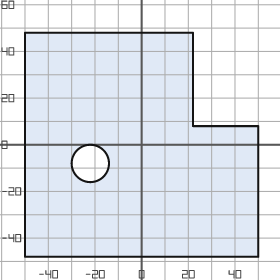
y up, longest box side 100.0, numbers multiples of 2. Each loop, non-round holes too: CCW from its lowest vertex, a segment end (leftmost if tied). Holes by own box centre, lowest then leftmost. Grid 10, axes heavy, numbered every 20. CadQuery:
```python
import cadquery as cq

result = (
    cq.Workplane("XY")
    .moveTo(-50.0, -48.0)
    .lineTo(50.0, -48.0)
    .lineTo(50.0, 8.0)
    .lineTo(22.0, 8.0)
    .lineTo(22.0, 48.0)
    .lineTo(-50.0, 48.0)
    .close()
    .moveTo(-22.0, -8.0)
    .circle(8.0)
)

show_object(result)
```